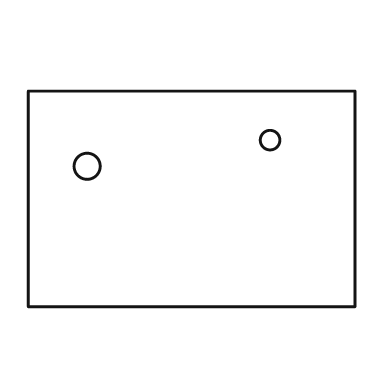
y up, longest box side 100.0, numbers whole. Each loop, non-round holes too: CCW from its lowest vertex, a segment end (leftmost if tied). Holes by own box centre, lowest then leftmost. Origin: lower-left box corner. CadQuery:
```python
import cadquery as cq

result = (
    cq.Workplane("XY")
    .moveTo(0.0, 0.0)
    .lineTo(100.0, 0.0)
    .lineTo(100.0, 66.0)
    .lineTo(0.0, 66.0)
    .close()
    .moveTo(18.0, 43.0)
    .circle(4.0)
    .moveTo(74.0, 51.0)
    .circle(3.0)
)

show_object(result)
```